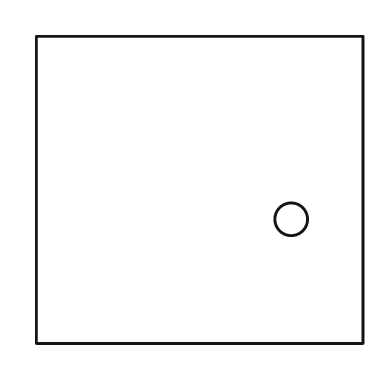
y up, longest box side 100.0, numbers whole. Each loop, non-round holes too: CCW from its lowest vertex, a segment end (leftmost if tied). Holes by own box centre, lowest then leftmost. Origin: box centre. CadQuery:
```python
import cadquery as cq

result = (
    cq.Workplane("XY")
    .moveTo(-50.0, -47.0)
    .lineTo(50.0, -47.0)
    .lineTo(50.0, 47.0)
    .lineTo(-50.0, 47.0)
    .close()
    .moveTo(28.0, -9.0)
    .circle(5.0)
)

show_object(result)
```